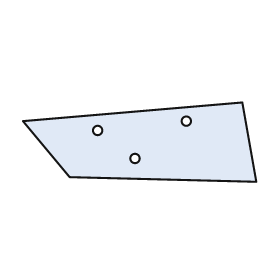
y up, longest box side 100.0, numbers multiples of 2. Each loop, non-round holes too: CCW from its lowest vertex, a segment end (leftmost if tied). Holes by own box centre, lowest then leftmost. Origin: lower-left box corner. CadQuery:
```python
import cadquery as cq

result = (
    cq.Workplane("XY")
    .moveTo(100.0, 0.0)
    .lineTo(94.0, 34.0)
    .lineTo(0.0, 26.0)
    .lineTo(20.0, 2.0)
    .close()
    .moveTo(48.0, 10.0)
    .circle(2.0)
    .moveTo(32.0, 22.0)
    .circle(2.0)
    .moveTo(70.0, 26.0)
    .circle(2.0)
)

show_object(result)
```